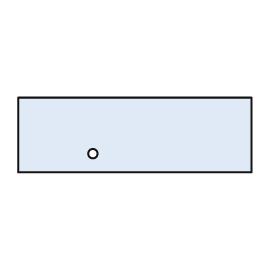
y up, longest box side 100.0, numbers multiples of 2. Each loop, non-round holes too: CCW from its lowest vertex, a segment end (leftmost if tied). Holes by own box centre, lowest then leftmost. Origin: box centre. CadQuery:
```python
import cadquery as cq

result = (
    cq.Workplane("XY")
    .moveTo(-50.0, -16.0)
    .lineTo(50.0, -16.0)
    .lineTo(50.0, 16.0)
    .lineTo(-50.0, 16.0)
    .close()
    .moveTo(-18.0, -8.0)
    .circle(2.0)
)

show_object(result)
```